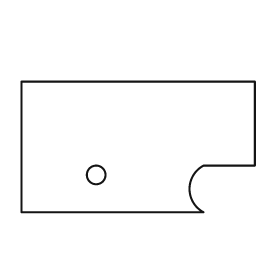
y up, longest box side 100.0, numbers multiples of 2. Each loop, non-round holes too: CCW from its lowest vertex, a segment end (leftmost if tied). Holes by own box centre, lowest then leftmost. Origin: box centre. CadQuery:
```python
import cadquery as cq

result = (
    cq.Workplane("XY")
    .moveTo(-50.0, -28.0)
    .lineTo(28.0, -28.0)
    .threePointArc((22.0, -18.0), (28.0, -8.0))
    .lineTo(50.0, -8.0)
    .lineTo(50.0, 28.0)
    .lineTo(-50.0, 28.0)
    .close()
    .moveTo(-18.0, -12.0)
    .circle(4.0)
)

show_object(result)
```